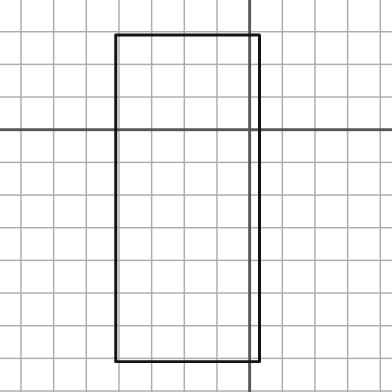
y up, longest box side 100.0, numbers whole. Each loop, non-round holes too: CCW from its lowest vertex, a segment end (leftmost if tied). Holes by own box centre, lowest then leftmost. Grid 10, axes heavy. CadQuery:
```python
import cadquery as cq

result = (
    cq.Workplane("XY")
    .moveTo(-41.0, -71.0)
    .lineTo(3.0, -71.0)
    .lineTo(3.0, 29.0)
    .lineTo(-41.0, 29.0)
    .close()
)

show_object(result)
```